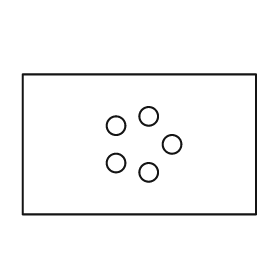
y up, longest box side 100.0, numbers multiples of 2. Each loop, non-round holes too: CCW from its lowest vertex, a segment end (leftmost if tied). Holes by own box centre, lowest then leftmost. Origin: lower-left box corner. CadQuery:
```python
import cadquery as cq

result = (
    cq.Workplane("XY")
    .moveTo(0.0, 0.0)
    .lineTo(100.0, 0.0)
    .lineTo(100.0, 60.0)
    .lineTo(0.0, 60.0)
    .close()
    .moveTo(54.0, 18.0)
    .circle(4.0)
    .moveTo(40.0, 22.0)
    .circle(4.0)
    .moveTo(64.0, 30.0)
    .circle(4.0)
    .moveTo(40.0, 38.0)
    .circle(4.0)
    .moveTo(54.0, 42.0)
    .circle(4.0)
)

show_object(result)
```